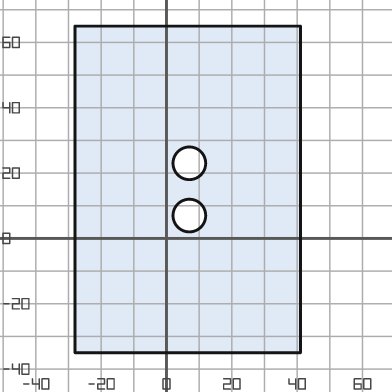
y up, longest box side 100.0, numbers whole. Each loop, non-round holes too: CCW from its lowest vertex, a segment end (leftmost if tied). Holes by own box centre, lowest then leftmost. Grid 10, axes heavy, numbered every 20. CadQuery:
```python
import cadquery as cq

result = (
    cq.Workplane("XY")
    .moveTo(-28.0, -35.0)
    .lineTo(41.0, -35.0)
    .lineTo(41.0, 65.0)
    .lineTo(-28.0, 65.0)
    .close()
    .moveTo(7.0, 7.0)
    .circle(5.0)
    .moveTo(7.0, 23.0)
    .circle(5.0)
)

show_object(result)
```